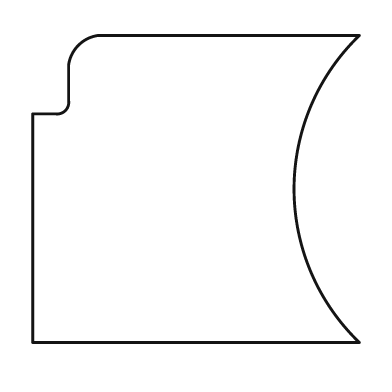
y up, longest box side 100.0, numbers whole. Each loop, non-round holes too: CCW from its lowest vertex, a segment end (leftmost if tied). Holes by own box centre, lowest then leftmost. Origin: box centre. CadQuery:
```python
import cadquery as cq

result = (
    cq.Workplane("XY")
    .moveTo(-50.0, -47.0)
    .lineTo(50.0, -47.0)
    .threePointArc((30.0, 0.0), (50.0, 47.0))
    .lineTo(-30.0, 47.0)
    .threePointArc((-36.0, 44.0), (-39.0, 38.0))
    .lineTo(-39.0, 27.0)
    .threePointArc((-40.0, 24.0), (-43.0, 23.0))
    .lineTo(-50.0, 23.0)
    .close()
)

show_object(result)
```